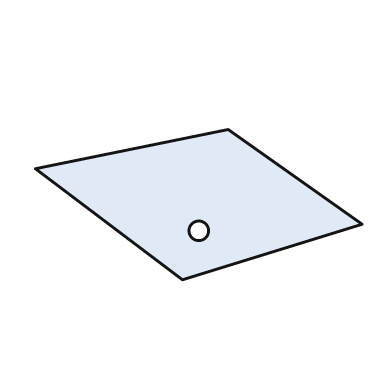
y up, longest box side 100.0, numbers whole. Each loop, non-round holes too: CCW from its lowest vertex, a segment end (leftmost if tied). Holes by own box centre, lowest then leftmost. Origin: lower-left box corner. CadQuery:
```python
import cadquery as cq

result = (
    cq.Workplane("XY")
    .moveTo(45.0, 0.0)
    .lineTo(100.0, 17.0)
    .lineTo(59.0, 46.0)
    .lineTo(0.0, 34.0)
    .close()
    .moveTo(50.0, 15.0)
    .circle(3.0)
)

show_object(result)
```